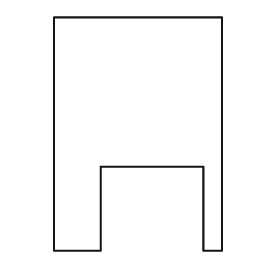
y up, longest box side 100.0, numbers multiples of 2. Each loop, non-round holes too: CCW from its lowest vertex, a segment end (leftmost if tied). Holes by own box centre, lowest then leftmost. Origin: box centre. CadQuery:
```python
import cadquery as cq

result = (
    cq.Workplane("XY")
    .moveTo(-36.0, -50.0)
    .lineTo(-16.0, -50.0)
    .lineTo(-16.0, -14.0)
    .lineTo(28.0, -14.0)
    .lineTo(28.0, -50.0)
    .lineTo(36.0, -50.0)
    .lineTo(36.0, 50.0)
    .lineTo(-36.0, 50.0)
    .close()
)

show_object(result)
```